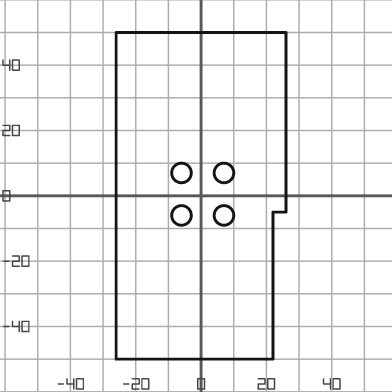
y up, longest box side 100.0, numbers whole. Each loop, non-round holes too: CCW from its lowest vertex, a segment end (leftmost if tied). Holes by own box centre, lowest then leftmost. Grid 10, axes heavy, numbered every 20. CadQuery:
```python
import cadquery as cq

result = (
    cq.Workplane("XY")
    .moveTo(-26.0, -50.0)
    .lineTo(22.0, -50.0)
    .lineTo(22.0, -5.0)
    .lineTo(26.0, -5.0)
    .lineTo(26.0, 50.0)
    .lineTo(-26.0, 50.0)
    .close()
    .moveTo(-6.0, -6.0)
    .circle(3.0)
    .moveTo(7.0, -6.0)
    .circle(3.0)
    .moveTo(-6.0, 7.0)
    .circle(3.0)
    .moveTo(7.0, 7.0)
    .circle(3.0)
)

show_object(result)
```